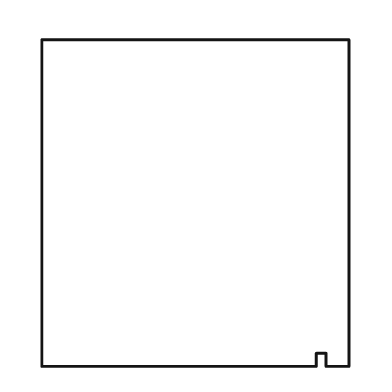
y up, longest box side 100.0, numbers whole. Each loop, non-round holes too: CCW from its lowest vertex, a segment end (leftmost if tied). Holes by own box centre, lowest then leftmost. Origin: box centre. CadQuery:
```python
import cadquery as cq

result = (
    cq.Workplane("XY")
    .moveTo(-47.0, -50.0)
    .lineTo(37.0, -50.0)
    .lineTo(37.0, -46.0)
    .lineTo(40.0, -46.0)
    .lineTo(40.0, -50.0)
    .lineTo(47.0, -50.0)
    .lineTo(47.0, 50.0)
    .lineTo(-47.0, 50.0)
    .close()
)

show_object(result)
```